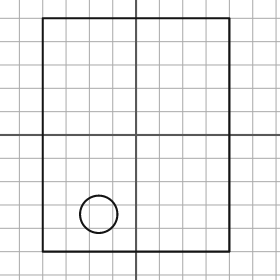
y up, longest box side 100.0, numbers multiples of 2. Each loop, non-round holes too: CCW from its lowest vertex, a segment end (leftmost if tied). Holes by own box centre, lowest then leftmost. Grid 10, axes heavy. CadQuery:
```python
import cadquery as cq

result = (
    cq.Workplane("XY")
    .moveTo(-40.0, -50.0)
    .lineTo(40.0, -50.0)
    .lineTo(40.0, 50.0)
    .lineTo(-40.0, 50.0)
    .close()
    .moveTo(-16.0, -34.0)
    .circle(8.0)
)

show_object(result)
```